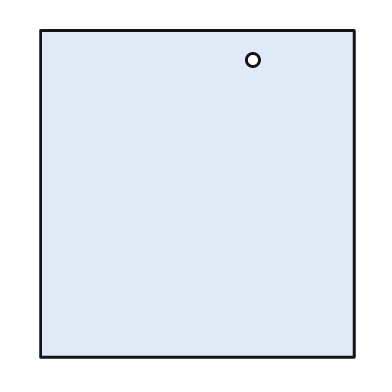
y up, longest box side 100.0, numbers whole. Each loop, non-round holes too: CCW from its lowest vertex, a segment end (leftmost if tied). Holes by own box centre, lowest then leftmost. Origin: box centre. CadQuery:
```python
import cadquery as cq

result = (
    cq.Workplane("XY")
    .moveTo(-48.0, -50.0)
    .lineTo(48.0, -50.0)
    .lineTo(48.0, 50.0)
    .lineTo(-48.0, 50.0)
    .close()
    .moveTo(17.0, 41.0)
    .circle(2.0)
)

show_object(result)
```